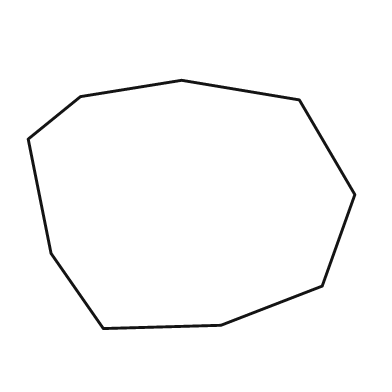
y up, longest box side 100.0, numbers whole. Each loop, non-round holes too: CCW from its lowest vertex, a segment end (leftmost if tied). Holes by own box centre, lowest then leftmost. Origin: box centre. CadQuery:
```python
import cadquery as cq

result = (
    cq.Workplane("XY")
    .moveTo(-27.0, -38.0)
    .lineTo(9.0, -37.0)
    .lineTo(40.0, -25.0)
    .lineTo(50.0, 3.0)
    .lineTo(33.0, 32.0)
    .lineTo(-3.0, 38.0)
    .lineTo(-34.0, 33.0)
    .lineTo(-50.0, 20.0)
    .lineTo(-43.0, -15.0)
    .close()
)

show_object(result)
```